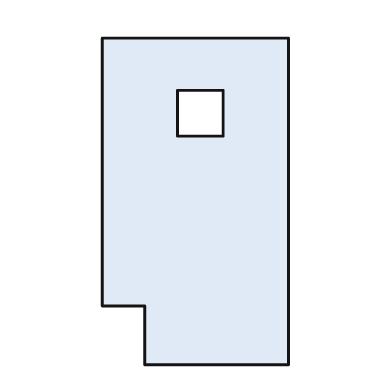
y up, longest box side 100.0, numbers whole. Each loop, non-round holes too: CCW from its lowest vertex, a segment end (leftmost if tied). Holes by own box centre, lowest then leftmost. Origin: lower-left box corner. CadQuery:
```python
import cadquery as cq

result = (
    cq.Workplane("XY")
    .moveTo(13.0, 0.0)
    .lineTo(57.0, 0.0)
    .lineTo(57.0, 100.0)
    .lineTo(0.0, 100.0)
    .lineTo(0.0, 18.0)
    .lineTo(13.0, 18.0)
    .close()
    .moveTo(23.0, 70.0)
    .lineTo(37.0, 70.0)
    .lineTo(37.0, 84.0)
    .lineTo(23.0, 84.0)
    .close()
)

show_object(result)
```